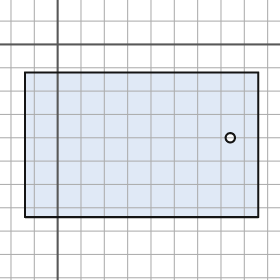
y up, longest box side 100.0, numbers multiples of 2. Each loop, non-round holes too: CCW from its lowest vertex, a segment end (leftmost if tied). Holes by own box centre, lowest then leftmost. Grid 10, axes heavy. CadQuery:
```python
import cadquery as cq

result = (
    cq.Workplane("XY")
    .moveTo(-14.0, -74.0)
    .lineTo(86.0, -74.0)
    .lineTo(86.0, -12.0)
    .lineTo(-14.0, -12.0)
    .close()
    .moveTo(74.0, -40.0)
    .circle(2.0)
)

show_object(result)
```